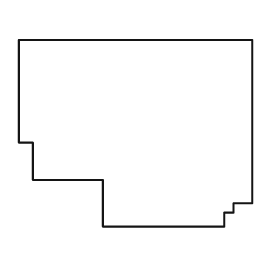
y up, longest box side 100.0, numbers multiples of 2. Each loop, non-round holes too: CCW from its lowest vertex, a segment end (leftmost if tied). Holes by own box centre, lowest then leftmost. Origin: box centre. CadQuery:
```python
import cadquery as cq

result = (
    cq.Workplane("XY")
    .moveTo(-14.0, -40.0)
    .lineTo(38.0, -40.0)
    .lineTo(38.0, -34.0)
    .lineTo(42.0, -34.0)
    .lineTo(42.0, -30.0)
    .lineTo(50.0, -30.0)
    .lineTo(50.0, 40.0)
    .lineTo(-50.0, 40.0)
    .lineTo(-50.0, -4.0)
    .lineTo(-44.0, -4.0)
    .lineTo(-44.0, -20.0)
    .lineTo(-14.0, -20.0)
    .close()
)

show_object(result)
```